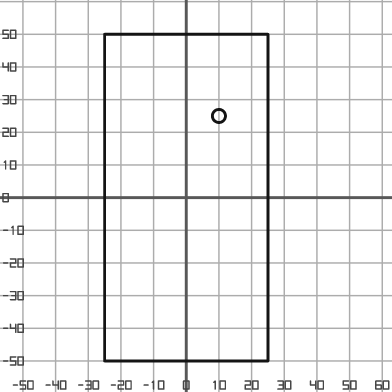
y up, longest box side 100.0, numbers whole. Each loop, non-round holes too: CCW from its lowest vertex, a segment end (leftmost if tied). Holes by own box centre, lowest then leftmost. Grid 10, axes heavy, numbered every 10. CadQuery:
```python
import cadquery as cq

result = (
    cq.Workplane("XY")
    .moveTo(-25.0, -50.0)
    .lineTo(25.0, -50.0)
    .lineTo(25.0, 50.0)
    .lineTo(-25.0, 50.0)
    .close()
    .moveTo(10.0, 25.0)
    .circle(2.0)
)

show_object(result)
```